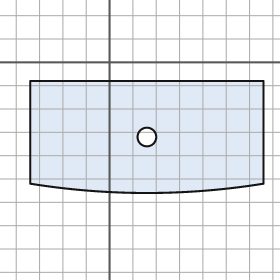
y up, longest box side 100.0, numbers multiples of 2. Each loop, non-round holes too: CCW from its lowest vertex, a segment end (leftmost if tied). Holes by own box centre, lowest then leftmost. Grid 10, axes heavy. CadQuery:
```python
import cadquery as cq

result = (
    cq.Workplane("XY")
    .moveTo(-34.0, -52.0)
    .threePointArc((16.0, -56.0), (66.0, -52.0))
    .lineTo(66.0, -8.0)
    .lineTo(-34.0, -8.0)
    .close()
    .moveTo(16.0, -32.0)
    .circle(4.0)
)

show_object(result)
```